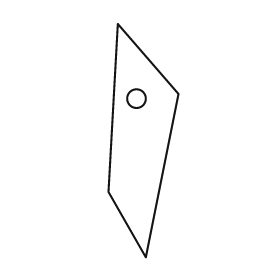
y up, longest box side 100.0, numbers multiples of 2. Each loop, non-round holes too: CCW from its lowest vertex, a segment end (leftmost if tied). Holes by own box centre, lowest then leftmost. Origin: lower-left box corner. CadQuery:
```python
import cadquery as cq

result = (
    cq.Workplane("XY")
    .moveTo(16.0, 0.0)
    .lineTo(30.0, 70.0)
    .lineTo(4.0, 100.0)
    .lineTo(0.0, 28.0)
    .close()
    .moveTo(12.0, 68.0)
    .circle(4.0)
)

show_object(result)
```